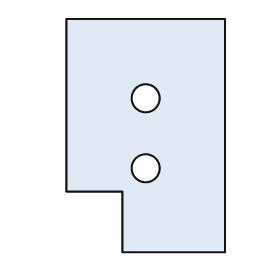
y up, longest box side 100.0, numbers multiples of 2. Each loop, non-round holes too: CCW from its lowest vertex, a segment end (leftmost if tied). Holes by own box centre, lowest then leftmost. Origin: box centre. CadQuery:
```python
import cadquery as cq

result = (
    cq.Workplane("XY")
    .moveTo(-10.0, -50.0)
    .lineTo(34.0, -50.0)
    .lineTo(34.0, 50.0)
    .lineTo(-34.0, 50.0)
    .lineTo(-34.0, -24.0)
    .lineTo(-10.0, -24.0)
    .close()
    .moveTo(0.0, -14.0)
    .circle(6.0)
    .moveTo(0.0, 16.0)
    .circle(6.0)
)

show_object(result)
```